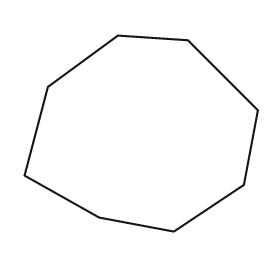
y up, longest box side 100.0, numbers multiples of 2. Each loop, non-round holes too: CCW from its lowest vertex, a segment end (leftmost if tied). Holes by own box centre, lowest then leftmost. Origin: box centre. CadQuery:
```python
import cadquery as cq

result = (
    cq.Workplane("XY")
    .moveTo(14.0, -42.0)
    .lineTo(44.0, -22.0)
    .lineTo(50.0, 10.0)
    .lineTo(20.0, 40.0)
    .lineTo(-10.0, 42.0)
    .lineTo(-40.0, 20.0)
    .lineTo(-50.0, -18.0)
    .lineTo(-18.0, -36.0)
    .close()
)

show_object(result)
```